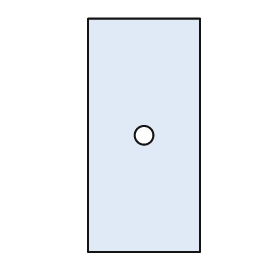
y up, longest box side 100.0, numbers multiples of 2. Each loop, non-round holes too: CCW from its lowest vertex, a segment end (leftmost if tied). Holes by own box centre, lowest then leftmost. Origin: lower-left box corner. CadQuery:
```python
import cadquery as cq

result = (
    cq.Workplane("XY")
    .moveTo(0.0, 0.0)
    .lineTo(48.0, 0.0)
    .lineTo(48.0, 100.0)
    .lineTo(0.0, 100.0)
    .close()
    .moveTo(24.0, 50.0)
    .circle(4.0)
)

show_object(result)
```